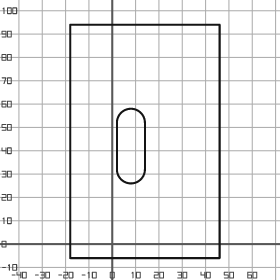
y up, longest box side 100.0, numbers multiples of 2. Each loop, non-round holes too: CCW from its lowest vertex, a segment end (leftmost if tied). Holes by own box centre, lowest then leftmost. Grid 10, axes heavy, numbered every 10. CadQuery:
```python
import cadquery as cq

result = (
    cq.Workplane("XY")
    .moveTo(-18.0, -6.0)
    .lineTo(46.0, -6.0)
    .lineTo(46.0, 94.0)
    .lineTo(-18.0, 94.0)
    .close()
    .moveTo(2.0, 32.0)
    .threePointArc((8.0, 26.0), (14.0, 32.0))
    .lineTo(14.0, 52.0)
    .threePointArc((8.0, 58.0), (2.0, 52.0))
    .close()
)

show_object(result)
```